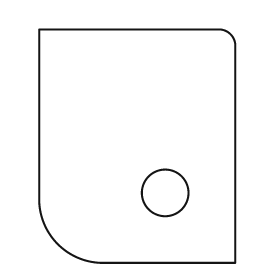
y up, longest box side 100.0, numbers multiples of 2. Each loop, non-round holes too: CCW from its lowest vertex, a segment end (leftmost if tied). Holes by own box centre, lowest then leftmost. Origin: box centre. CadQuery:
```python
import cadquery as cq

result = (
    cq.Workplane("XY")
    .moveTo(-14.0, -50.0)
    .lineTo(42.0, -50.0)
    .lineTo(42.0, 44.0)
    .threePointArc((40.0, 48.0), (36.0, 50.0))
    .lineTo(-42.0, 50.0)
    .lineTo(-42.0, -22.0)
    .threePointArc((-34.0, -42.0), (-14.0, -50.0))
    .close()
    .moveTo(12.0, -20.0)
    .circle(10.0)
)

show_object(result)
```